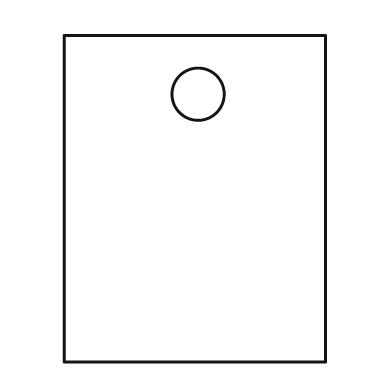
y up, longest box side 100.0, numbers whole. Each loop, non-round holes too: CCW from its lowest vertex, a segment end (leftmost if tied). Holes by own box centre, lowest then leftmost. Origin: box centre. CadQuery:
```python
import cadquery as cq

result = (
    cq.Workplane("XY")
    .moveTo(-40.0, -50.0)
    .lineTo(40.0, -50.0)
    .lineTo(40.0, 50.0)
    .lineTo(-40.0, 50.0)
    .close()
    .moveTo(1.0, 32.0)
    .circle(8.0)
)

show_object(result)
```